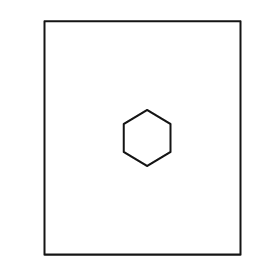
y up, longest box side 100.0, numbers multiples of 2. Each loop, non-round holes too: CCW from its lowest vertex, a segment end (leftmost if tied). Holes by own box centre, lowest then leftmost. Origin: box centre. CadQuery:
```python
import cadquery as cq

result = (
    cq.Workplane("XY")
    .moveTo(-42.0, -50.0)
    .lineTo(42.0, -50.0)
    .lineTo(42.0, 50.0)
    .lineTo(-42.0, 50.0)
    .close()
    .moveTo(2.0, -12.0)
    .lineTo(12.0, -6.0)
    .lineTo(12.0, 6.0)
    .lineTo(2.0, 12.0)
    .lineTo(-8.0, 6.0)
    .lineTo(-8.0, -6.0)
    .close()
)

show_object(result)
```